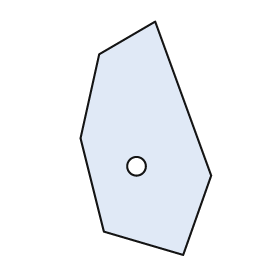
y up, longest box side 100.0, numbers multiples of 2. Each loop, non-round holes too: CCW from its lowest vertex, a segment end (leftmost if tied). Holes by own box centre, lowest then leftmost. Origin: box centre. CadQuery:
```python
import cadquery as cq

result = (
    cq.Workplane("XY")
    .moveTo(16.0, -50.0)
    .lineTo(28.0, -16.0)
    .lineTo(4.0, 50.0)
    .lineTo(-20.0, 36.0)
    .lineTo(-28.0, 0.0)
    .lineTo(-18.0, -40.0)
    .close()
    .moveTo(-4.0, -12.0)
    .circle(4.0)
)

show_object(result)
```